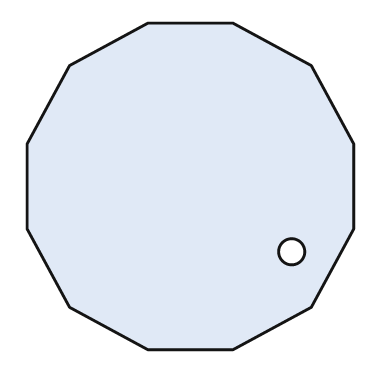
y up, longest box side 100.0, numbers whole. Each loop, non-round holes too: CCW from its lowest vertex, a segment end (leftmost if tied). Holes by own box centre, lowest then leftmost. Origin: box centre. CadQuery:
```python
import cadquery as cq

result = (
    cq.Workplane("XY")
    .moveTo(-13.0, -50.0)
    .lineTo(13.0, -50.0)
    .lineTo(37.0, -37.0)
    .lineTo(50.0, -13.0)
    .lineTo(50.0, 13.0)
    .lineTo(37.0, 37.0)
    .lineTo(13.0, 50.0)
    .lineTo(-13.0, 50.0)
    .lineTo(-37.0, 37.0)
    .lineTo(-50.0, 13.0)
    .lineTo(-50.0, -13.0)
    .lineTo(-37.0, -37.0)
    .close()
    .moveTo(31.0, -20.0)
    .circle(4.0)
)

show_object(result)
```